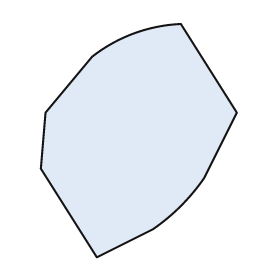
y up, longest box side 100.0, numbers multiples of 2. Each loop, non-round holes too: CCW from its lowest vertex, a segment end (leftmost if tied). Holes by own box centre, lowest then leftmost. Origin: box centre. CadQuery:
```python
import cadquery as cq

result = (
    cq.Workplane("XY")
    .moveTo(-18.0, -50.0)
    .lineTo(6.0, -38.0)
    .threePointArc((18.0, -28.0), (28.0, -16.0))
    .lineTo(42.0, 12.0)
    .lineTo(18.0, 50.0)
    .threePointArc((-2.0, 46.0), (-20.0, 36.0))
    .lineTo(-40.0, 12.0)
    .lineTo(-42.0, -12.0)
    .close()
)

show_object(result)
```